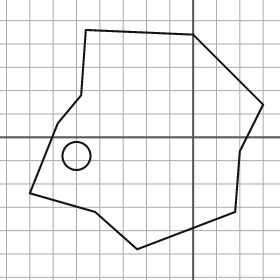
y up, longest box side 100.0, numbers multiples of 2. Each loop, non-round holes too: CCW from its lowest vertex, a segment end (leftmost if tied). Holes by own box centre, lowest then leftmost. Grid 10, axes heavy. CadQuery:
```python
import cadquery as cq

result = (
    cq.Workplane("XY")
    .moveTo(-24.0, -48.0)
    .lineTo(18.0, -32.0)
    .lineTo(20.0, -6.0)
    .lineTo(30.0, 14.0)
    .lineTo(0.0, 44.0)
    .lineTo(-46.0, 46.0)
    .lineTo(-48.0, 18.0)
    .lineTo(-58.0, 6.0)
    .lineTo(-70.0, -24.0)
    .lineTo(-42.0, -32.0)
    .close()
    .moveTo(-50.0, -8.0)
    .circle(6.0)
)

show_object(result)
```